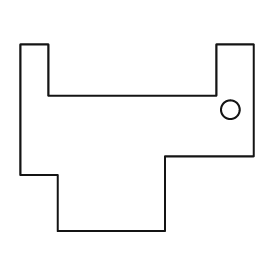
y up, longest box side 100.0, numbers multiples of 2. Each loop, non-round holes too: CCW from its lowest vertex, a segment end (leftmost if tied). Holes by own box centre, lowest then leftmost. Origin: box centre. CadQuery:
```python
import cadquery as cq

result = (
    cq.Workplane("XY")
    .moveTo(-34.0, -40.0)
    .lineTo(12.0, -40.0)
    .lineTo(12.0, -8.0)
    .lineTo(50.0, -8.0)
    .lineTo(50.0, 40.0)
    .lineTo(34.0, 40.0)
    .lineTo(34.0, 18.0)
    .lineTo(-38.0, 18.0)
    .lineTo(-38.0, 40.0)
    .lineTo(-50.0, 40.0)
    .lineTo(-50.0, -16.0)
    .lineTo(-34.0, -16.0)
    .close()
    .moveTo(40.0, 12.0)
    .circle(4.0)
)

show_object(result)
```